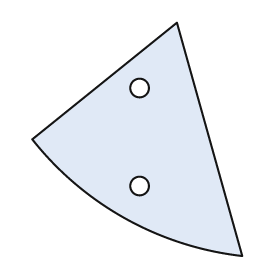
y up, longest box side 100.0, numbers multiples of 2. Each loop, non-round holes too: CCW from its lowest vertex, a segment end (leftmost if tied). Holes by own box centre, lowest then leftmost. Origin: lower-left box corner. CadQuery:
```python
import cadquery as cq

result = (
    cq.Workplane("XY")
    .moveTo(90.0, 0.0)
    .lineTo(62.0, 100.0)
    .lineTo(0.0, 50.0)
    .threePointArc((40.0, 16.0), (90.0, 0.0))
    .close()
    .moveTo(46.0, 30.0)
    .circle(4.0)
    .moveTo(46.0, 72.0)
    .circle(4.0)
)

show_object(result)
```